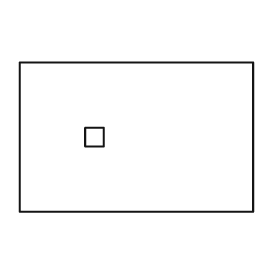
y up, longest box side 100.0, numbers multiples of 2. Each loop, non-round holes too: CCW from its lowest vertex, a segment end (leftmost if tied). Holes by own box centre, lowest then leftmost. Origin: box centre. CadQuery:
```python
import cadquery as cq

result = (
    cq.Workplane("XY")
    .moveTo(-50.0, -32.0)
    .lineTo(50.0, -32.0)
    .lineTo(50.0, 32.0)
    .lineTo(-50.0, 32.0)
    .close()
    .moveTo(-22.0, -4.0)
    .lineTo(-14.0, -4.0)
    .lineTo(-14.0, 4.0)
    .lineTo(-22.0, 4.0)
    .close()
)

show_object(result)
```